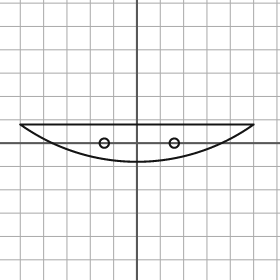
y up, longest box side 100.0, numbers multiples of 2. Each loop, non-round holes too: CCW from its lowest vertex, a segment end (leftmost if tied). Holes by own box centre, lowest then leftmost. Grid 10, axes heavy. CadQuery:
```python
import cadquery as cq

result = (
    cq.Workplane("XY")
    .moveTo(-50.0, 8.0)
    .threePointArc((0.0, -8.0), (50.0, 8.0))
    .close()
    .moveTo(-14.0, 0.0)
    .circle(2.0)
    .moveTo(16.0, 0.0)
    .circle(2.0)
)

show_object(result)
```